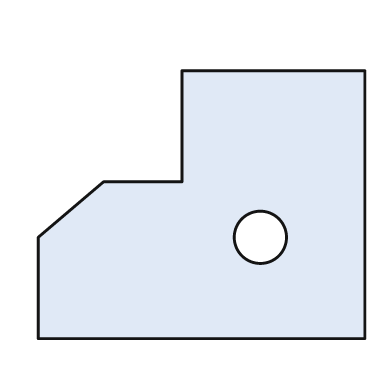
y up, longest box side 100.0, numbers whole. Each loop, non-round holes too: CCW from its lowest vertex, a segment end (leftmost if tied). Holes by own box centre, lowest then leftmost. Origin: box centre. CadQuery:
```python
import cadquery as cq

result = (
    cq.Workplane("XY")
    .moveTo(-50.0, -41.0)
    .lineTo(50.0, -41.0)
    .lineTo(50.0, 41.0)
    .lineTo(-6.0, 41.0)
    .lineTo(-6.0, 7.0)
    .lineTo(-30.0, 7.0)
    .lineTo(-50.0, -10.0)
    .close()
    .moveTo(18.0, -10.0)
    .circle(8.0)
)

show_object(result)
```